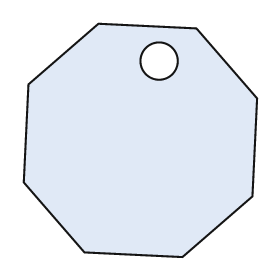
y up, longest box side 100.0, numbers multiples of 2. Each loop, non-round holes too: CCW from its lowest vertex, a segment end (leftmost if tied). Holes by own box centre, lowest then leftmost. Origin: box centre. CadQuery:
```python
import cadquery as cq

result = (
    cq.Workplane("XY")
    .moveTo(18.0, -50.0)
    .lineTo(48.0, -24.0)
    .lineTo(50.0, 18.0)
    .lineTo(24.0, 48.0)
    .lineTo(-18.0, 50.0)
    .lineTo(-48.0, 24.0)
    .lineTo(-50.0, -18.0)
    .lineTo(-24.0, -48.0)
    .close()
    .moveTo(8.0, 34.0)
    .circle(8.0)
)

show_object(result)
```